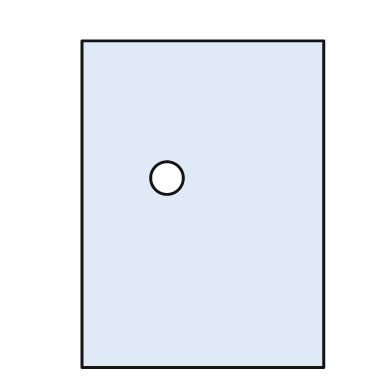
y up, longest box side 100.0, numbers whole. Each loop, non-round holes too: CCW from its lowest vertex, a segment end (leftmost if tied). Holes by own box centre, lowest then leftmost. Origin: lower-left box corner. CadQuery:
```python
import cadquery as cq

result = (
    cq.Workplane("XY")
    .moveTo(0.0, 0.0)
    .lineTo(74.0, 0.0)
    .lineTo(74.0, 100.0)
    .lineTo(0.0, 100.0)
    .close()
    .moveTo(26.0, 58.0)
    .circle(5.0)
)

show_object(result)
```